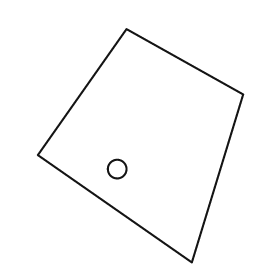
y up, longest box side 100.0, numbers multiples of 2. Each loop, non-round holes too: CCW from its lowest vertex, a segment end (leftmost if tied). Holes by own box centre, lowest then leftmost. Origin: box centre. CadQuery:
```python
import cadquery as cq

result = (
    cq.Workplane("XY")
    .moveTo(22.0, -50.0)
    .lineTo(44.0, 22.0)
    .lineTo(-6.0, 50.0)
    .lineTo(-44.0, -4.0)
    .close()
    .moveTo(-10.0, -10.0)
    .circle(4.0)
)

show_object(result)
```